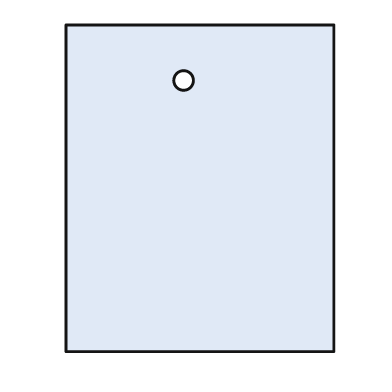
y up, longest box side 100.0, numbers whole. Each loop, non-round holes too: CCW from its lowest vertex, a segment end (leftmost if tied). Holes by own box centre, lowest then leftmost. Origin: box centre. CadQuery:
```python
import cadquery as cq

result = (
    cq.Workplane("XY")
    .moveTo(-41.0, -50.0)
    .lineTo(41.0, -50.0)
    .lineTo(41.0, 50.0)
    .lineTo(-41.0, 50.0)
    .close()
    .moveTo(-5.0, 33.0)
    .circle(3.0)
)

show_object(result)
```